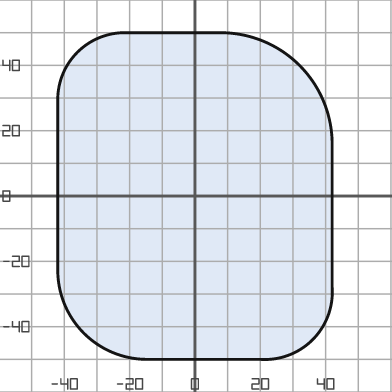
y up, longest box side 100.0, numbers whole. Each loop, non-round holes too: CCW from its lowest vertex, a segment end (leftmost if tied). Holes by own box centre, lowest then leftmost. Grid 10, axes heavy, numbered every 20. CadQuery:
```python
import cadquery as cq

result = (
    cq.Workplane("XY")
    .moveTo(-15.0, -50.0)
    .lineTo(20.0, -50.0)
    .threePointArc((36.0, -44.0), (42.0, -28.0))
    .lineTo(42.0, 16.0)
    .threePointArc((32.0, 40.0), (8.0, 50.0))
    .lineTo(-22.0, 50.0)
    .threePointArc((-36.0, 44.0), (-42.0, 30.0))
    .lineTo(-42.0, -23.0)
    .threePointArc((-34.0, -42.0), (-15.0, -50.0))
    .close()
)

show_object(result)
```